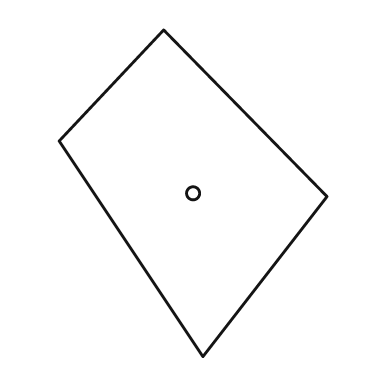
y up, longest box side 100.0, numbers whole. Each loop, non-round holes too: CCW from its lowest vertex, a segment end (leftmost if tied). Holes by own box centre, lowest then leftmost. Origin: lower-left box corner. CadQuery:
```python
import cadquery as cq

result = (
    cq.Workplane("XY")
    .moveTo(44.0, 0.0)
    .lineTo(82.0, 49.0)
    .lineTo(32.0, 100.0)
    .lineTo(0.0, 66.0)
    .close()
    .moveTo(41.0, 50.0)
    .circle(2.0)
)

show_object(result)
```